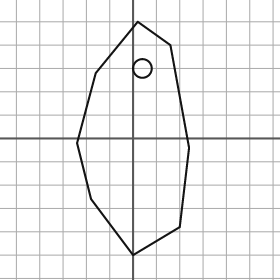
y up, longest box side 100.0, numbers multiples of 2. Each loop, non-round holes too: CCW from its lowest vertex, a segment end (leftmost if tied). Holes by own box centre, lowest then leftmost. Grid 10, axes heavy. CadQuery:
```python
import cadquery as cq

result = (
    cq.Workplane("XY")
    .moveTo(0.0, -50.0)
    .lineTo(20.0, -38.0)
    .lineTo(24.0, -4.0)
    .lineTo(16.0, 40.0)
    .lineTo(2.0, 50.0)
    .lineTo(-16.0, 28.0)
    .lineTo(-24.0, -2.0)
    .lineTo(-18.0, -26.0)
    .close()
    .moveTo(4.0, 30.0)
    .circle(4.0)
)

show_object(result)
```